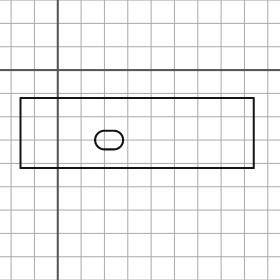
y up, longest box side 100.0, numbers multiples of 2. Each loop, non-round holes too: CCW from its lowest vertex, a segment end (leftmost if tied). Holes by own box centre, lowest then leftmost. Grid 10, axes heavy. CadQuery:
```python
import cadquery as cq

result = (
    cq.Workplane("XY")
    .moveTo(-16.0, -42.0)
    .lineTo(84.0, -42.0)
    .lineTo(84.0, -12.0)
    .lineTo(-16.0, -12.0)
    .close()
    .moveTo(20.0, -34.0)
    .lineTo(24.0, -34.0)
    .threePointArc((28.0, -30.0), (24.0, -26.0))
    .lineTo(20.0, -26.0)
    .threePointArc((16.0, -30.0), (20.0, -34.0))
    .close()
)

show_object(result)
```